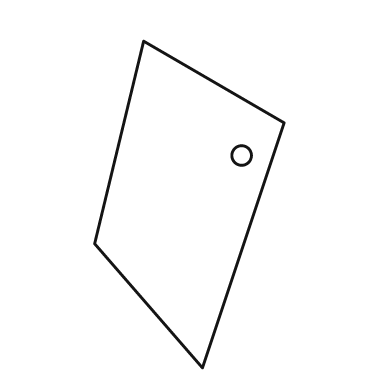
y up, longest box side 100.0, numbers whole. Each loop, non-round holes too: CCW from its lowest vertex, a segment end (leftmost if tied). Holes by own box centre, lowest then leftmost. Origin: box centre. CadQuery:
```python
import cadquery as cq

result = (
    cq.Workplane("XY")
    .moveTo(4.0, -50.0)
    .lineTo(29.0, 25.0)
    .lineTo(-14.0, 50.0)
    .lineTo(-29.0, -12.0)
    .close()
    .moveTo(16.0, 15.0)
    .circle(3.0)
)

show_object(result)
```